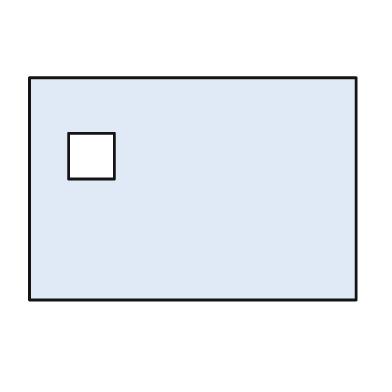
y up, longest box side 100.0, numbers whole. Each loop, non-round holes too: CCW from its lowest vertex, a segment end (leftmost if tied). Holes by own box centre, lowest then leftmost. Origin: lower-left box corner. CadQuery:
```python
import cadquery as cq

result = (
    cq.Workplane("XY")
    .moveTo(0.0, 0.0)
    .lineTo(100.0, 0.0)
    .lineTo(100.0, 68.0)
    .lineTo(0.0, 68.0)
    .close()
    .moveTo(12.0, 37.0)
    .lineTo(26.0, 37.0)
    .lineTo(26.0, 51.0)
    .lineTo(12.0, 51.0)
    .close()
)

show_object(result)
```